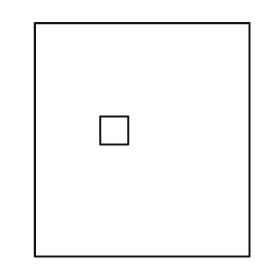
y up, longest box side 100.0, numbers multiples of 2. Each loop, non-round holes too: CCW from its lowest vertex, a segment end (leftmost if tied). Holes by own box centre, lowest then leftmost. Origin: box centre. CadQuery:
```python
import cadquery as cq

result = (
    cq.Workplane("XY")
    .moveTo(-46.0, -50.0)
    .lineTo(46.0, -50.0)
    .lineTo(46.0, 50.0)
    .lineTo(-46.0, 50.0)
    .close()
    .moveTo(-18.0, -2.0)
    .lineTo(-6.0, -2.0)
    .lineTo(-6.0, 10.0)
    .lineTo(-18.0, 10.0)
    .close()
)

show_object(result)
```